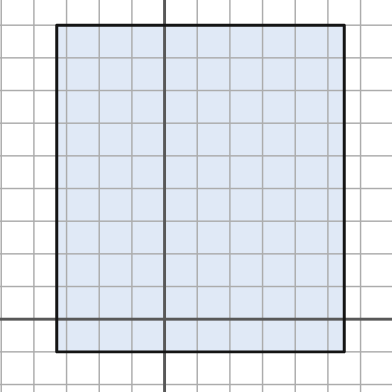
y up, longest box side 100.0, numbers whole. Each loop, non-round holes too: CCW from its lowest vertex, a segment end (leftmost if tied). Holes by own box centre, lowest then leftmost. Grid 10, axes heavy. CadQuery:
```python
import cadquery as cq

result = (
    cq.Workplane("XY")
    .moveTo(-33.0, -10.0)
    .lineTo(55.0, -10.0)
    .lineTo(55.0, 90.0)
    .lineTo(-33.0, 90.0)
    .close()
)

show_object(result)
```